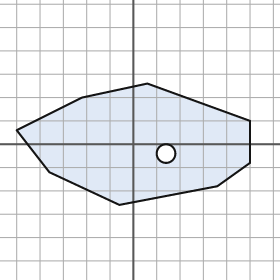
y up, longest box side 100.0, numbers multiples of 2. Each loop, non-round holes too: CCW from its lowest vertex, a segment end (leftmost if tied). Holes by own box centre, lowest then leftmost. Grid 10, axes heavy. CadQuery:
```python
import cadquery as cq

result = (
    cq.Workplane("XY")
    .moveTo(-6.0, -26.0)
    .lineTo(36.0, -18.0)
    .lineTo(50.0, -8.0)
    .lineTo(50.0, 10.0)
    .lineTo(6.0, 26.0)
    .lineTo(-22.0, 20.0)
    .lineTo(-50.0, 6.0)
    .lineTo(-36.0, -12.0)
    .close()
    .moveTo(14.0, -4.0)
    .circle(4.0)
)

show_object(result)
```